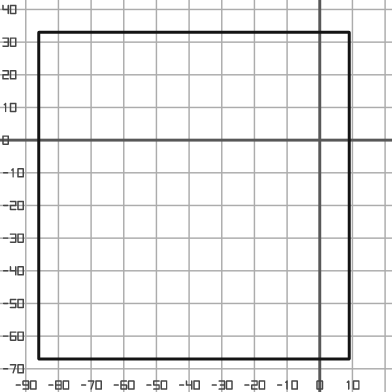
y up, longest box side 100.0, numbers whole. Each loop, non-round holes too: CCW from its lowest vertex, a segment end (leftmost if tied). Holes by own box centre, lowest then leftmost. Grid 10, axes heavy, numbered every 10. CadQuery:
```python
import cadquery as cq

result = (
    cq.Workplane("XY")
    .moveTo(-86.0, -67.0)
    .lineTo(9.0, -67.0)
    .lineTo(9.0, 33.0)
    .lineTo(-86.0, 33.0)
    .close()
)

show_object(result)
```